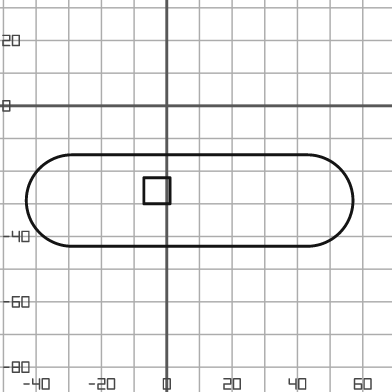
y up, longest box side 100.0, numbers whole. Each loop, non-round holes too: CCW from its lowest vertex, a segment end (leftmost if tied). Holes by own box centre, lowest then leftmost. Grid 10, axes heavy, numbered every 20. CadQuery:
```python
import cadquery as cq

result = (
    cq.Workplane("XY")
    .moveTo(-29.0, -43.0)
    .lineTo(43.0, -43.0)
    .threePointArc((57.0, -29.0), (43.0, -15.0))
    .lineTo(-29.0, -15.0)
    .threePointArc((-43.0, -29.0), (-29.0, -43.0))
    .close()
    .moveTo(-7.0, -30.0)
    .lineTo(1.0, -30.0)
    .lineTo(1.0, -22.0)
    .lineTo(-7.0, -22.0)
    .close()
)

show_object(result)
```